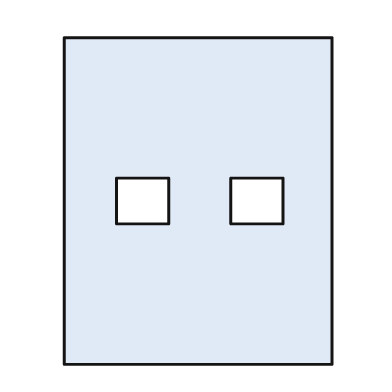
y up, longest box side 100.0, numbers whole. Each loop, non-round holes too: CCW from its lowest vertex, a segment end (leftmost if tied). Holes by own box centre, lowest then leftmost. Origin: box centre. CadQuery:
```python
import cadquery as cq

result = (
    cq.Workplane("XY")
    .moveTo(-41.0, -50.0)
    .lineTo(41.0, -50.0)
    .lineTo(41.0, 50.0)
    .lineTo(-41.0, 50.0)
    .close()
    .moveTo(-25.0, -7.0)
    .lineTo(-9.0, -7.0)
    .lineTo(-9.0, 7.0)
    .lineTo(-25.0, 7.0)
    .close()
    .moveTo(10.0, -7.0)
    .lineTo(26.0, -7.0)
    .lineTo(26.0, 7.0)
    .lineTo(10.0, 7.0)
    .close()
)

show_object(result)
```